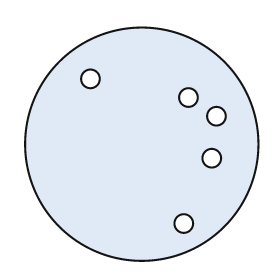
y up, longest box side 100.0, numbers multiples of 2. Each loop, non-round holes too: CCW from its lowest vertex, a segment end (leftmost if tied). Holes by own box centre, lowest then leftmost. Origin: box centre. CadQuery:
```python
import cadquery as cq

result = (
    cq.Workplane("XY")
    .moveTo(0.0, 0.0)
    .circle(50.0)
    .moveTo(18.0, -34.0)
    .circle(4.0)
    .moveTo(30.0, -6.0)
    .circle(4.0)
    .moveTo(32.0, 12.0)
    .circle(4.0)
    .moveTo(20.0, 20.0)
    .circle(4.0)
    .moveTo(-22.0, 28.0)
    .circle(4.0)
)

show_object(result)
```